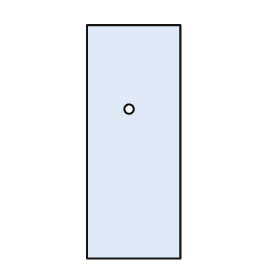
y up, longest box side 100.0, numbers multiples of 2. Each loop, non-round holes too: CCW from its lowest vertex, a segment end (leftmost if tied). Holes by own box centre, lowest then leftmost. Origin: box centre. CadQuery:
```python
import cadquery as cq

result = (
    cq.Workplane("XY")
    .moveTo(-20.0, -50.0)
    .lineTo(20.0, -50.0)
    .lineTo(20.0, 50.0)
    .lineTo(-20.0, 50.0)
    .close()
    .moveTo(-2.0, 14.0)
    .circle(2.0)
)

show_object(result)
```